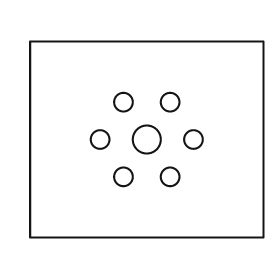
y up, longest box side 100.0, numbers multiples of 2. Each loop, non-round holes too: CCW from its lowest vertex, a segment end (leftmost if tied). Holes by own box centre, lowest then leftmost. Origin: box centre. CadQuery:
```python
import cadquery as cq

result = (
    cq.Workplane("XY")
    .moveTo(-50.0, -42.0)
    .lineTo(50.0, -42.0)
    .lineTo(50.0, 42.0)
    .lineTo(-50.0, 42.0)
    .close()
    .moveTo(-10.0, -16.0)
    .circle(4.0)
    .moveTo(10.0, -16.0)
    .circle(4.0)
    .moveTo(-20.0, 0.0)
    .circle(4.0)
    .moveTo(0.0, 0.0)
    .circle(6.0)
    .moveTo(20.0, 0.0)
    .circle(4.0)
    .moveTo(-10.0, 16.0)
    .circle(4.0)
    .moveTo(10.0, 16.0)
    .circle(4.0)
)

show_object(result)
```